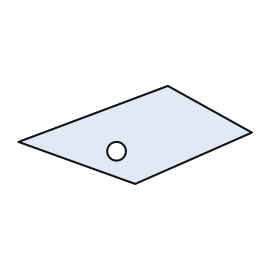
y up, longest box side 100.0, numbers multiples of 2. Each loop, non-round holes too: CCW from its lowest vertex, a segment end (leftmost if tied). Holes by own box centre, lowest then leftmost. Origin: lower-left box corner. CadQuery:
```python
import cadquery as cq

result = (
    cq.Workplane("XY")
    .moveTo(50.0, 0.0)
    .lineTo(100.0, 22.0)
    .lineTo(64.0, 42.0)
    .lineTo(0.0, 18.0)
    .close()
    .moveTo(42.0, 14.0)
    .circle(4.0)
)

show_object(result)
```